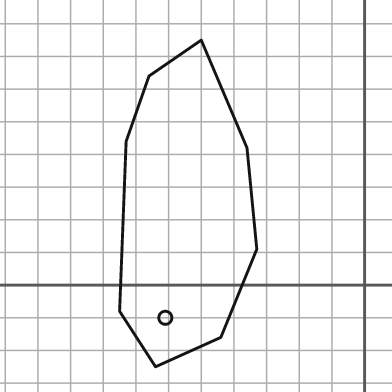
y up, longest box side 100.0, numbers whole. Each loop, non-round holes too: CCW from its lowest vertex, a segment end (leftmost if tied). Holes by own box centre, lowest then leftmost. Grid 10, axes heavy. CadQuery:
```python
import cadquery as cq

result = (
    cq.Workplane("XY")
    .moveTo(-64.0, -25.0)
    .lineTo(-44.0, -16.0)
    .lineTo(-33.0, 11.0)
    .lineTo(-36.0, 42.0)
    .lineTo(-50.0, 75.0)
    .lineTo(-66.0, 64.0)
    .lineTo(-73.0, 44.0)
    .lineTo(-75.0, -8.0)
    .close()
    .moveTo(-61.0, -10.0)
    .circle(2.0)
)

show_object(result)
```